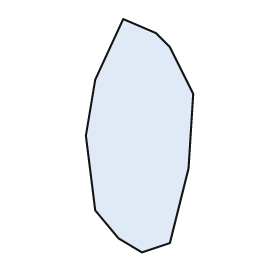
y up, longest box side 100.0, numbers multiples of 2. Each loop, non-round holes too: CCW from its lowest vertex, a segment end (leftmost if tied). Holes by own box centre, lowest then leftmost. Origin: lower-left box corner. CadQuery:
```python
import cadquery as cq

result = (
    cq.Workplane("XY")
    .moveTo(24.0, 0.0)
    .lineTo(36.0, 4.0)
    .lineTo(44.0, 36.0)
    .lineTo(46.0, 68.0)
    .lineTo(36.0, 88.0)
    .lineTo(30.0, 94.0)
    .lineTo(16.0, 100.0)
    .lineTo(4.0, 74.0)
    .lineTo(0.0, 50.0)
    .lineTo(4.0, 18.0)
    .lineTo(14.0, 6.0)
    .close()
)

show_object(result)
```